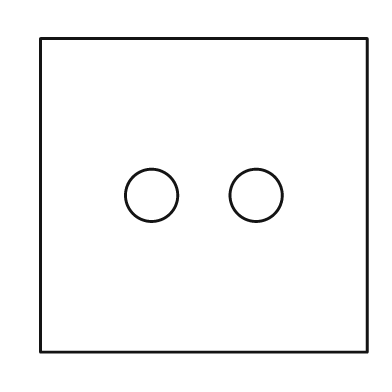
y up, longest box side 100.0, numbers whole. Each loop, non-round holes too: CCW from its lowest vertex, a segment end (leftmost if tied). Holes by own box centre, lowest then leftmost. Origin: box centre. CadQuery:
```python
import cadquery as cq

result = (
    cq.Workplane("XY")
    .moveTo(-50.0, -48.0)
    .lineTo(50.0, -48.0)
    .lineTo(50.0, 48.0)
    .lineTo(-50.0, 48.0)
    .close()
    .moveTo(-16.0, 0.0)
    .circle(8.0)
    .moveTo(16.0, 0.0)
    .circle(8.0)
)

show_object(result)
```